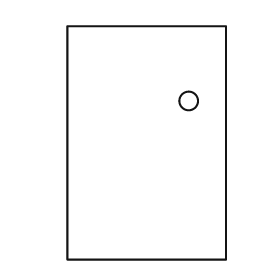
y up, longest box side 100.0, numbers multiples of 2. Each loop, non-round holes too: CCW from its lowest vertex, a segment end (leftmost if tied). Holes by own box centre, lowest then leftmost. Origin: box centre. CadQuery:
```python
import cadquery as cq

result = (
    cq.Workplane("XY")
    .moveTo(-34.0, -50.0)
    .lineTo(34.0, -50.0)
    .lineTo(34.0, 50.0)
    .lineTo(-34.0, 50.0)
    .close()
    .moveTo(18.0, 18.0)
    .circle(4.0)
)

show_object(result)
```